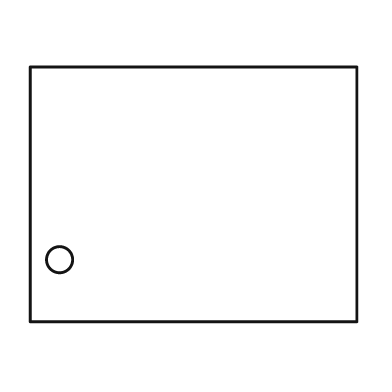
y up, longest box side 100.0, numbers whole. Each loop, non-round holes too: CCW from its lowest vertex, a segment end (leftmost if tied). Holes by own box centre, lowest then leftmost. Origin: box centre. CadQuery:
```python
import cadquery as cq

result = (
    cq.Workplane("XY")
    .moveTo(-50.0, -39.0)
    .lineTo(50.0, -39.0)
    .lineTo(50.0, 39.0)
    .lineTo(-50.0, 39.0)
    .close()
    .moveTo(-41.0, -20.0)
    .circle(4.0)
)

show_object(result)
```